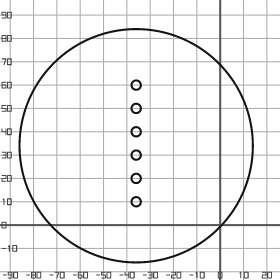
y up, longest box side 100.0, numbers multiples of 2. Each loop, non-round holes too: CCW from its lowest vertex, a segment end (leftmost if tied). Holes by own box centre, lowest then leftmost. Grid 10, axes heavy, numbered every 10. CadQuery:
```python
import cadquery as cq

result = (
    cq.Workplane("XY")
    .moveTo(-36.0, 34.0)
    .circle(50.0)
    .moveTo(-36.0, 10.0)
    .circle(2.0)
    .moveTo(-36.0, 20.0)
    .circle(2.0)
    .moveTo(-36.0, 30.0)
    .circle(2.0)
    .moveTo(-36.0, 40.0)
    .circle(2.0)
    .moveTo(-36.0, 50.0)
    .circle(2.0)
    .moveTo(-36.0, 60.0)
    .circle(2.0)
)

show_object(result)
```